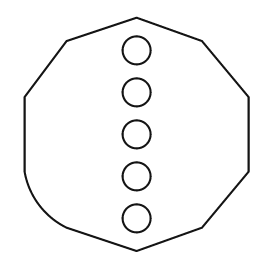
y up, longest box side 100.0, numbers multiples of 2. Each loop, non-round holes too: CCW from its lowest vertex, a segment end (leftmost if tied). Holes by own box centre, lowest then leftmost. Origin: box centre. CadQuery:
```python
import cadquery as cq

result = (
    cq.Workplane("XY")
    .moveTo(0.0, -50.0)
    .lineTo(28.0, -40.0)
    .lineTo(48.0, -16.0)
    .lineTo(48.0, 16.0)
    .lineTo(28.0, 40.0)
    .lineTo(0.0, 50.0)
    .lineTo(-30.0, 40.0)
    .lineTo(-48.0, 16.0)
    .lineTo(-48.0, -16.0)
    .threePointArc((-42.0, -30.0), (-30.0, -40.0))
    .close()
    .moveTo(0.0, -36.0)
    .circle(6.0)
    .moveTo(0.0, -18.0)
    .circle(6.0)
    .moveTo(0.0, 0.0)
    .circle(6.0)
    .moveTo(0.0, 18.0)
    .circle(6.0)
    .moveTo(0.0, 36.0)
    .circle(6.0)
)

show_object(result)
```